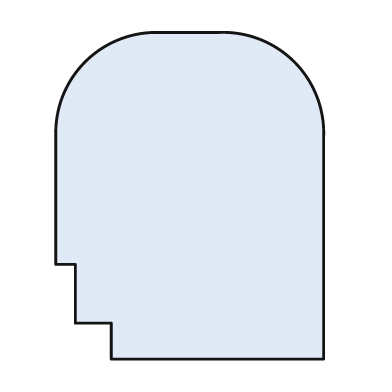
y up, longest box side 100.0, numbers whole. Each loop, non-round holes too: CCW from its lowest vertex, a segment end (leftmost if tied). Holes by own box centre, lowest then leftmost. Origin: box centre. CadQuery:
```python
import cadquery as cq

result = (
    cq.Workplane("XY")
    .moveTo(-24.0, -50.0)
    .lineTo(41.0, -50.0)
    .lineTo(41.0, 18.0)
    .threePointArc((32.0, 41.0), (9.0, 50.0))
    .lineTo(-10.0, 50.0)
    .threePointArc((-32.0, 41.0), (-41.0, 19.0))
    .lineTo(-41.0, -21.0)
    .lineTo(-35.0, -21.0)
    .lineTo(-35.0, -39.0)
    .lineTo(-24.0, -39.0)
    .close()
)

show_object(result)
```